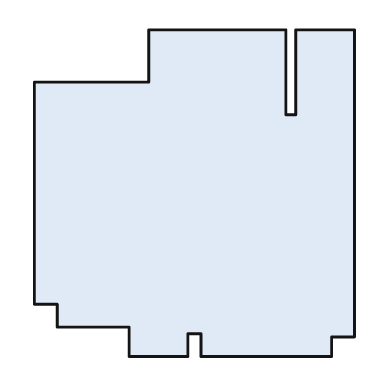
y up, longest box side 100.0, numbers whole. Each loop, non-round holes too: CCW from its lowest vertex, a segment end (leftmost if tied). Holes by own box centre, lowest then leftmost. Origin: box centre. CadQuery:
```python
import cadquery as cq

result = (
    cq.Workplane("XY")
    .moveTo(-20.0, -50.0)
    .lineTo(-2.0, -50.0)
    .lineTo(-2.0, -43.0)
    .lineTo(2.0, -43.0)
    .lineTo(2.0, -50.0)
    .lineTo(42.0, -50.0)
    .lineTo(42.0, -44.0)
    .lineTo(49.0, -44.0)
    .lineTo(49.0, 50.0)
    .lineTo(31.0, 50.0)
    .lineTo(31.0, 24.0)
    .lineTo(28.0, 24.0)
    .lineTo(28.0, 50.0)
    .lineTo(-14.0, 50.0)
    .lineTo(-14.0, 34.0)
    .lineTo(-49.0, 34.0)
    .lineTo(-49.0, -34.0)
    .lineTo(-42.0, -34.0)
    .lineTo(-42.0, -41.0)
    .lineTo(-20.0, -41.0)
    .close()
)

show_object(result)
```